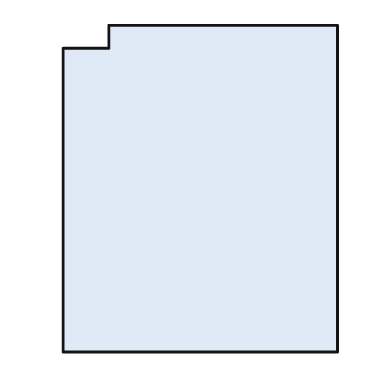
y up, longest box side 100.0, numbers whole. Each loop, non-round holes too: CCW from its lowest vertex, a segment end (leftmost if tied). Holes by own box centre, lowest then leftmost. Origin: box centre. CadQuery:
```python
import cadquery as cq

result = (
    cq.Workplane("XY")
    .moveTo(-42.0, -50.0)
    .lineTo(42.0, -50.0)
    .lineTo(42.0, 50.0)
    .lineTo(-28.0, 50.0)
    .lineTo(-28.0, 43.0)
    .lineTo(-42.0, 43.0)
    .close()
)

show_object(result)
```